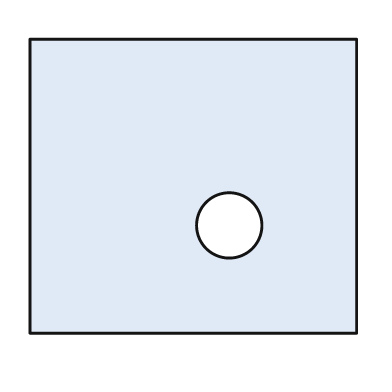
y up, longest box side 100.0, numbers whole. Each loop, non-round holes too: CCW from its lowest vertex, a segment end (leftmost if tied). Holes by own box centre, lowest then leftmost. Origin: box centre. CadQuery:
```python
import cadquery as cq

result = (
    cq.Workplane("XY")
    .moveTo(-50.0, -45.0)
    .lineTo(50.0, -45.0)
    .lineTo(50.0, 45.0)
    .lineTo(-50.0, 45.0)
    .close()
    .moveTo(11.0, -12.0)
    .circle(10.0)
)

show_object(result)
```